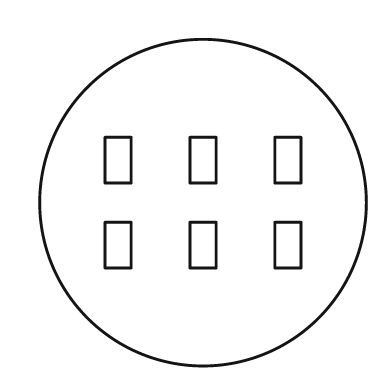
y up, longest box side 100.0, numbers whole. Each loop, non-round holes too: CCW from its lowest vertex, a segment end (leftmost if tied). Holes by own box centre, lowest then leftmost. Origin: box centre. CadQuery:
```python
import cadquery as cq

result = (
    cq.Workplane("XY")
    .moveTo(0.0, 0.0)
    .circle(50.0)
    .moveTo(-30.0, -20.0)
    .lineTo(-22.0, -20.0)
    .lineTo(-22.0, -6.0)
    .lineTo(-30.0, -6.0)
    .close()
    .moveTo(-4.0, -20.0)
    .lineTo(4.0, -20.0)
    .lineTo(4.0, -6.0)
    .lineTo(-4.0, -6.0)
    .close()
    .moveTo(22.0, -20.0)
    .lineTo(30.0, -20.0)
    .lineTo(30.0, -6.0)
    .lineTo(22.0, -6.0)
    .close()
    .moveTo(-30.0, 6.0)
    .lineTo(-22.0, 6.0)
    .lineTo(-22.0, 20.0)
    .lineTo(-30.0, 20.0)
    .close()
    .moveTo(-4.0, 6.0)
    .lineTo(4.0, 6.0)
    .lineTo(4.0, 20.0)
    .lineTo(-4.0, 20.0)
    .close()
    .moveTo(22.0, 6.0)
    .lineTo(30.0, 6.0)
    .lineTo(30.0, 20.0)
    .lineTo(22.0, 20.0)
    .close()
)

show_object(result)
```